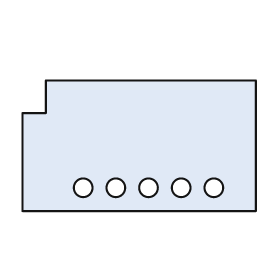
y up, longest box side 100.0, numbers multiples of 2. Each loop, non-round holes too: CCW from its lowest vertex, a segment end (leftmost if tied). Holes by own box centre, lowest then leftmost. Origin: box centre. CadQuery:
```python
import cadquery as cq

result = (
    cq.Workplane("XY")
    .moveTo(-50.0, -28.0)
    .lineTo(50.0, -28.0)
    .lineTo(50.0, 28.0)
    .lineTo(-40.0, 28.0)
    .lineTo(-40.0, 14.0)
    .lineTo(-50.0, 14.0)
    .close()
    .moveTo(-24.0, -18.0)
    .circle(4.0)
    .moveTo(-10.0, -18.0)
    .circle(4.0)
    .moveTo(4.0, -18.0)
    .circle(4.0)
    .moveTo(18.0, -18.0)
    .circle(4.0)
    .moveTo(32.0, -18.0)
    .circle(4.0)
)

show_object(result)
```